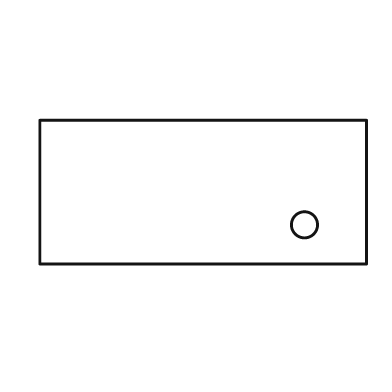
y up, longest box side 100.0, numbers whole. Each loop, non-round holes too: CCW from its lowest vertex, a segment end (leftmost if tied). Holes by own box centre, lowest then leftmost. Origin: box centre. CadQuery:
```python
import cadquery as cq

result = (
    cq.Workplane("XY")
    .moveTo(-50.0, -22.0)
    .lineTo(50.0, -22.0)
    .lineTo(50.0, 22.0)
    .lineTo(-50.0, 22.0)
    .close()
    .moveTo(31.0, -10.0)
    .circle(4.0)
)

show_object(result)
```